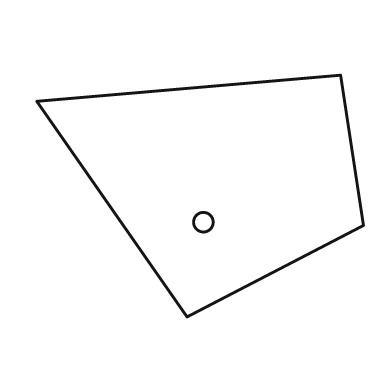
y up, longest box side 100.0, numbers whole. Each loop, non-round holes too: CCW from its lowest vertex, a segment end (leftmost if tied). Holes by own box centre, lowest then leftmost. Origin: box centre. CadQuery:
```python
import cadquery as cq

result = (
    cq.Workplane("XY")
    .moveTo(-4.0, -37.0)
    .lineTo(50.0, -9.0)
    .lineTo(43.0, 37.0)
    .lineTo(-50.0, 29.0)
    .close()
    .moveTo(1.0, -8.0)
    .circle(3.0)
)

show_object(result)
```